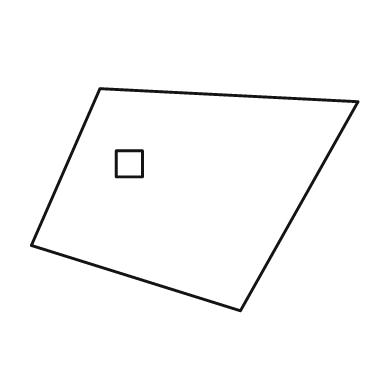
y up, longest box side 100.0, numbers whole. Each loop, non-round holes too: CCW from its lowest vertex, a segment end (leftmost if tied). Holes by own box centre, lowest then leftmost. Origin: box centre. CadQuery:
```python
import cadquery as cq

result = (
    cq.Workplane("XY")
    .moveTo(14.0, -34.0)
    .lineTo(50.0, 30.0)
    .lineTo(-29.0, 34.0)
    .lineTo(-50.0, -14.0)
    .close()
    .moveTo(-24.0, 7.0)
    .lineTo(-16.0, 7.0)
    .lineTo(-16.0, 15.0)
    .lineTo(-24.0, 15.0)
    .close()
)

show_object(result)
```